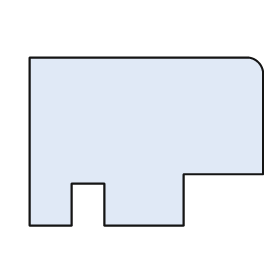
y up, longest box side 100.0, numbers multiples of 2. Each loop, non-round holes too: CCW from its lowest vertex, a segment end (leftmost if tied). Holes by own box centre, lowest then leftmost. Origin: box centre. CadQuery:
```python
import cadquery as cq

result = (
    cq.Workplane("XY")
    .moveTo(-50.0, -36.0)
    .lineTo(-32.0, -36.0)
    .lineTo(-32.0, -18.0)
    .lineTo(-18.0, -18.0)
    .lineTo(-18.0, -36.0)
    .lineTo(16.0, -36.0)
    .lineTo(16.0, -14.0)
    .lineTo(50.0, -14.0)
    .lineTo(50.0, 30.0)
    .threePointArc((48.0, 34.0), (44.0, 36.0))
    .lineTo(-50.0, 36.0)
    .close()
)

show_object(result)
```